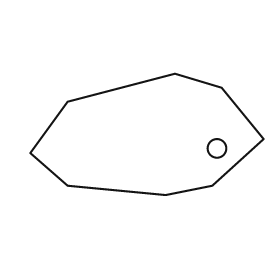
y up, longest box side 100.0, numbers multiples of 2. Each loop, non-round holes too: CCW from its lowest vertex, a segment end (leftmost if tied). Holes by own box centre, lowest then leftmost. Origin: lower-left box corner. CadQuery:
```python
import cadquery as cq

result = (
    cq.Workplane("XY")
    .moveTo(58.0, 0.0)
    .lineTo(78.0, 4.0)
    .lineTo(100.0, 24.0)
    .lineTo(82.0, 46.0)
    .lineTo(62.0, 52.0)
    .lineTo(16.0, 40.0)
    .lineTo(0.0, 18.0)
    .lineTo(16.0, 4.0)
    .close()
    .moveTo(80.0, 20.0)
    .circle(4.0)
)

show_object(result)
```